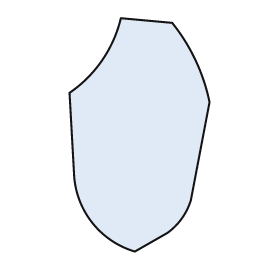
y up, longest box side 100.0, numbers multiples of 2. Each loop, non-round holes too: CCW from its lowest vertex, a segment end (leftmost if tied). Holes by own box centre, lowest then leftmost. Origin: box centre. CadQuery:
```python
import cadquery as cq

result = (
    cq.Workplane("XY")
    .moveTo(-2.0, -50.0)
    .lineTo(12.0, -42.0)
    .threePointArc((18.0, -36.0), (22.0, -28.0))
    .lineTo(30.0, 14.0)
    .threePointArc((24.0, 32.0), (14.0, 48.0))
    .lineTo(-8.0, 50.0)
    .threePointArc((-16.0, 32.0), (-30.0, 18.0))
    .lineTo(-28.0, -18.0)
    .threePointArc((-20.0, -38.0), (-2.0, -50.0))
    .close()
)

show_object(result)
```